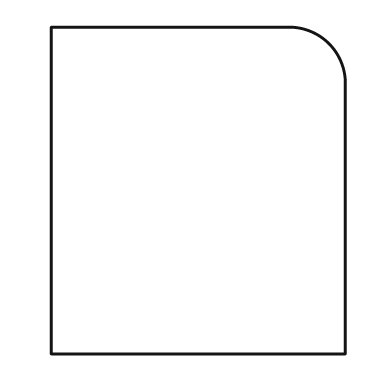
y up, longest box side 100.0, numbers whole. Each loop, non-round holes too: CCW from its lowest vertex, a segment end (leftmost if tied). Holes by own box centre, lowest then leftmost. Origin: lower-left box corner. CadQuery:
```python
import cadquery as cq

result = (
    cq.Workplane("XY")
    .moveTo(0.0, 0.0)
    .lineTo(90.0, 0.0)
    .lineTo(90.0, 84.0)
    .threePointArc((85.0, 95.0), (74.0, 100.0))
    .lineTo(0.0, 100.0)
    .close()
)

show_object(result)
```